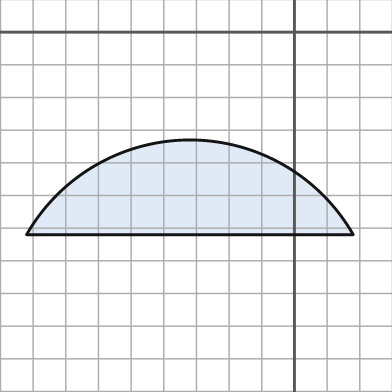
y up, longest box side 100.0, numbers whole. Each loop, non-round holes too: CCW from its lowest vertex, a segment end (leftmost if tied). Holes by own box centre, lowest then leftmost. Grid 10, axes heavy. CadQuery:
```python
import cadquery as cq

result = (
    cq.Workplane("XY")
    .moveTo(-82.0, -62.0)
    .lineTo(18.0, -62.0)
    .threePointArc((-32.0, -33.0), (-82.0, -62.0))
    .close()
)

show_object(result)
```